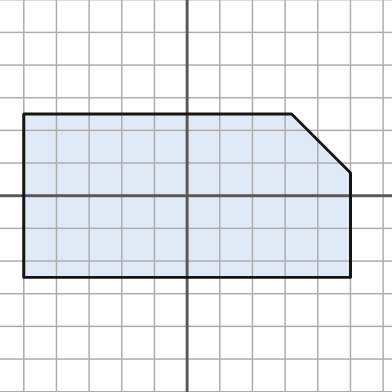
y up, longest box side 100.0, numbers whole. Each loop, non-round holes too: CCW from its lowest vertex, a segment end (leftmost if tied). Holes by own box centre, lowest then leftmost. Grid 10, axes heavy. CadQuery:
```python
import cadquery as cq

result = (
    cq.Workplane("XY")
    .moveTo(-50.0, -25.0)
    .lineTo(50.0, -25.0)
    .lineTo(50.0, 7.0)
    .lineTo(32.0, 25.0)
    .lineTo(-50.0, 25.0)
    .close()
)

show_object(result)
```